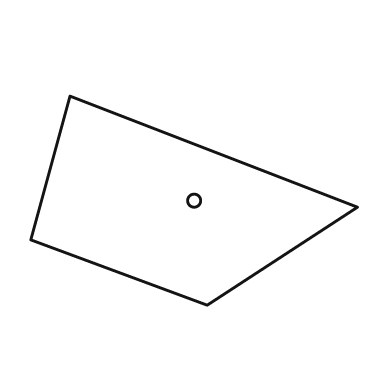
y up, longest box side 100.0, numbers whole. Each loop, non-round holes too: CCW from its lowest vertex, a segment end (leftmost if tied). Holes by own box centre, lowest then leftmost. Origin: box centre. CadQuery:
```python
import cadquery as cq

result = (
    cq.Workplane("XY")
    .moveTo(4.0, -32.0)
    .lineTo(50.0, -2.0)
    .lineTo(-38.0, 32.0)
    .lineTo(-50.0, -12.0)
    .close()
    .moveTo(0.0, 0.0)
    .circle(2.0)
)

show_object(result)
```